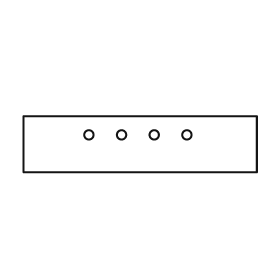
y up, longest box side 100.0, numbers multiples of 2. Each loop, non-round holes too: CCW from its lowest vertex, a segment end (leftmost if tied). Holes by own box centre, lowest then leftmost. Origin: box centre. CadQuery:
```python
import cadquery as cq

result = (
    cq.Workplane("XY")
    .moveTo(-50.0, -12.0)
    .lineTo(50.0, -12.0)
    .lineTo(50.0, 12.0)
    .lineTo(-50.0, 12.0)
    .close()
    .moveTo(-22.0, 4.0)
    .circle(2.0)
    .moveTo(-8.0, 4.0)
    .circle(2.0)
    .moveTo(6.0, 4.0)
    .circle(2.0)
    .moveTo(20.0, 4.0)
    .circle(2.0)
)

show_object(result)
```